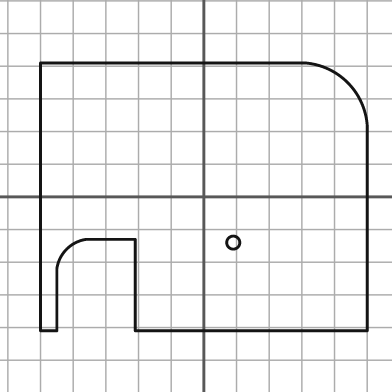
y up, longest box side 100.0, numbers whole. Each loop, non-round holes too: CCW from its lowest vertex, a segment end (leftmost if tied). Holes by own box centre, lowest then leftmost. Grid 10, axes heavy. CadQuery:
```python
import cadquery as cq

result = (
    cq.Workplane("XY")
    .moveTo(-50.0, -41.0)
    .lineTo(-45.0, -41.0)
    .lineTo(-45.0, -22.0)
    .threePointArc((-42.0, -16.0), (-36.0, -13.0))
    .lineTo(-21.0, -13.0)
    .lineTo(-21.0, -41.0)
    .lineTo(50.0, -41.0)
    .lineTo(50.0, 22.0)
    .threePointArc((44.0, 35.0), (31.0, 41.0))
    .lineTo(-50.0, 41.0)
    .close()
    .moveTo(9.0, -14.0)
    .circle(2.0)
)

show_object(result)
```